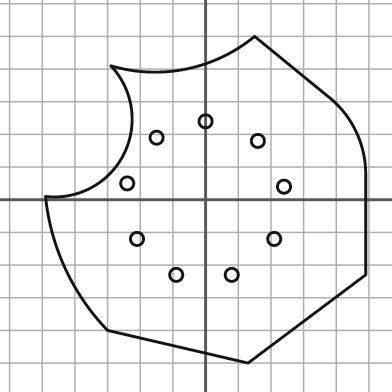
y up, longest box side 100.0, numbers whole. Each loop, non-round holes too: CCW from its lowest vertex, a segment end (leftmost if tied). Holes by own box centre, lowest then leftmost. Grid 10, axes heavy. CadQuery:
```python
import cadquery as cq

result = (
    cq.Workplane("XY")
    .moveTo(13.0, -50.0)
    .lineTo(49.0, -23.0)
    .lineTo(49.0, 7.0)
    .threePointArc((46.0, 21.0), (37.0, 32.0))
    .lineTo(15.0, 50.0)
    .threePointArc((-6.0, 40.0), (-29.0, 41.0))
    .threePointArc((-25.0, 14.0), (-49.0, 1.0))
    .threePointArc((-43.0, -21.0), (-30.0, -40.0))
    .close()
    .moveTo(-9.0, -23.0)
    .circle(2.0)
    .moveTo(8.0, -23.0)
    .circle(2.0)
    .moveTo(-21.0, -12.0)
    .circle(2.0)
    .moveTo(21.0, -12.0)
    .circle(2.0)
    .moveTo(24.0, 4.0)
    .circle(2.0)
    .moveTo(-24.0, 5.0)
    .circle(2.0)
    .moveTo(16.0, 18.0)
    .circle(2.0)
    .moveTo(-15.0, 19.0)
    .circle(2.0)
    .moveTo(0.0, 24.0)
    .circle(2.0)
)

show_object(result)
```